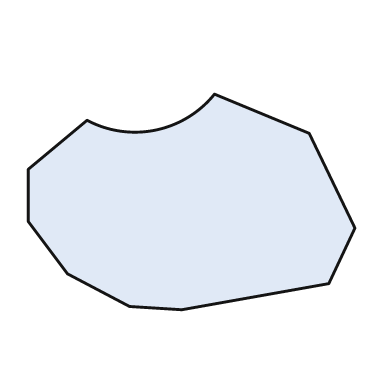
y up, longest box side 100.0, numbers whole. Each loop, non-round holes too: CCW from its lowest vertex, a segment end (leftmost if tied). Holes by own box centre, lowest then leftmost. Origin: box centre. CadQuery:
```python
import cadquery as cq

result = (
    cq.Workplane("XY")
    .moveTo(-3.0, -33.0)
    .lineTo(42.0, -25.0)
    .lineTo(50.0, -8.0)
    .lineTo(36.0, 21.0)
    .lineTo(7.0, 33.0)
    .threePointArc((-11.0, 22.0), (-32.0, 25.0))
    .lineTo(-50.0, 10.0)
    .lineTo(-50.0, -6.0)
    .lineTo(-38.0, -22.0)
    .lineTo(-19.0, -32.0)
    .close()
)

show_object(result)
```